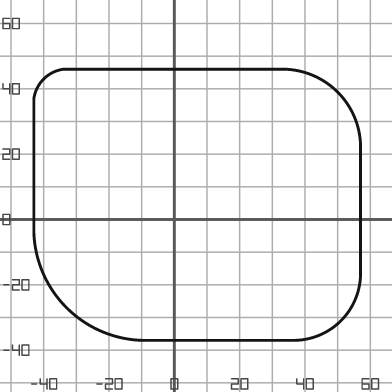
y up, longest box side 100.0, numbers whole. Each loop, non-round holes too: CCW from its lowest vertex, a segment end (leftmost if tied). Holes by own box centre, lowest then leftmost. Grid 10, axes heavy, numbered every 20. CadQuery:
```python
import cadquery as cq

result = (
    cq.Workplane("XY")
    .moveTo(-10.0, -37.0)
    .lineTo(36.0, -37.0)
    .threePointArc((51.0, -31.0), (57.0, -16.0))
    .lineTo(57.0, 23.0)
    .threePointArc((50.0, 39.0), (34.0, 46.0))
    .lineTo(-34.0, 46.0)
    .threePointArc((-40.0, 43.0), (-43.0, 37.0))
    .lineTo(-43.0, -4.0)
    .threePointArc((-33.0, -27.0), (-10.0, -37.0))
    .close()
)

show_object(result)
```